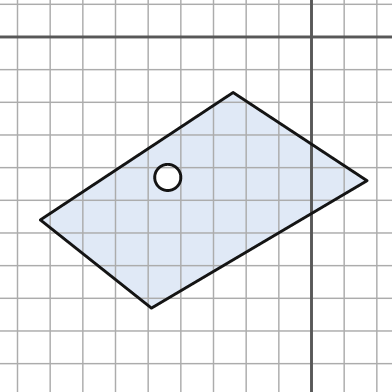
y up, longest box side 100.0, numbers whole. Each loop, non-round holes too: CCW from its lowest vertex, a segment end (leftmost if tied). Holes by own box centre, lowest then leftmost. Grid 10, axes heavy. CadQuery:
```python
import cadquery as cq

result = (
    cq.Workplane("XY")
    .moveTo(-49.0, -83.0)
    .lineTo(17.0, -44.0)
    .lineTo(-24.0, -17.0)
    .lineTo(-83.0, -56.0)
    .close()
    .moveTo(-44.0, -43.0)
    .circle(4.0)
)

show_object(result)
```